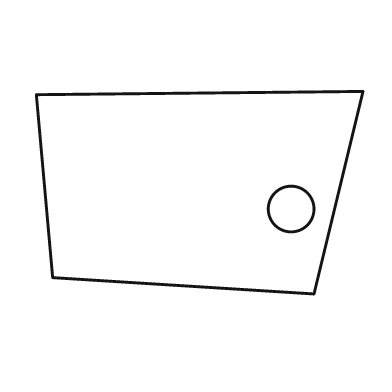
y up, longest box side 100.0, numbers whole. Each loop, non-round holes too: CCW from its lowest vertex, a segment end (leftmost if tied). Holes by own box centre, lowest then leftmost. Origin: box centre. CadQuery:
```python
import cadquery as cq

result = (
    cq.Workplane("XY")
    .moveTo(35.0, -31.0)
    .lineTo(50.0, 31.0)
    .lineTo(-50.0, 30.0)
    .lineTo(-45.0, -26.0)
    .close()
    .moveTo(28.0, -5.0)
    .circle(7.0)
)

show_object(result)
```